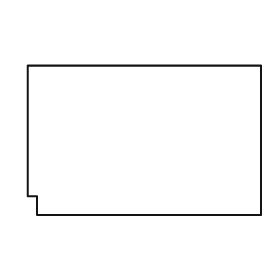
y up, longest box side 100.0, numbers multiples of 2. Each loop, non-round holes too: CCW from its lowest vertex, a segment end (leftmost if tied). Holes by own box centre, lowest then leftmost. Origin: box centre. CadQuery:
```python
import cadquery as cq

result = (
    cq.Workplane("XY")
    .moveTo(-46.0, -32.0)
    .lineTo(50.0, -32.0)
    .lineTo(50.0, 32.0)
    .lineTo(-50.0, 32.0)
    .lineTo(-50.0, -24.0)
    .lineTo(-46.0, -24.0)
    .close()
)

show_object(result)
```